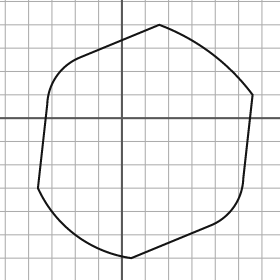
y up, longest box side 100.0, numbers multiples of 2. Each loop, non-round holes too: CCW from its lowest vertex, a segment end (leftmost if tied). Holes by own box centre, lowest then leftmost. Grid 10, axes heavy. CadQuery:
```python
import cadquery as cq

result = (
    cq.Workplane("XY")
    .moveTo(4.0, -60.0)
    .lineTo(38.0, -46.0)
    .threePointArc((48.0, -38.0), (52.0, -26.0))
    .lineTo(56.0, 10.0)
    .threePointArc((38.0, 28.0), (16.0, 40.0))
    .lineTo(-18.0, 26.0)
    .threePointArc((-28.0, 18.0), (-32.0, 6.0))
    .lineTo(-36.0, -30.0)
    .threePointArc((-20.0, -50.0), (4.0, -60.0))
    .close()
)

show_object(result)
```